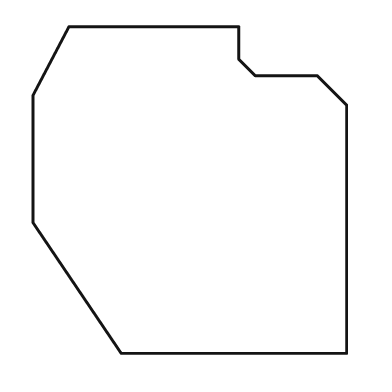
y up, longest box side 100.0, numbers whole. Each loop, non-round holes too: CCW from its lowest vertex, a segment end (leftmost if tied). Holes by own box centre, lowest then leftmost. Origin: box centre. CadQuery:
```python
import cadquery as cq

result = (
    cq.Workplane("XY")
    .moveTo(-21.0, -50.0)
    .lineTo(48.0, -50.0)
    .lineTo(48.0, 26.0)
    .lineTo(39.0, 35.0)
    .lineTo(20.0, 35.0)
    .lineTo(15.0, 40.0)
    .lineTo(15.0, 50.0)
    .lineTo(-37.0, 50.0)
    .lineTo(-48.0, 29.0)
    .lineTo(-48.0, -10.0)
    .close()
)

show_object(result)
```